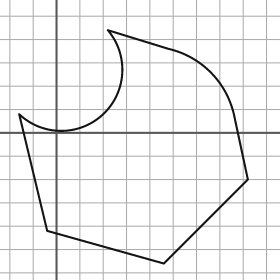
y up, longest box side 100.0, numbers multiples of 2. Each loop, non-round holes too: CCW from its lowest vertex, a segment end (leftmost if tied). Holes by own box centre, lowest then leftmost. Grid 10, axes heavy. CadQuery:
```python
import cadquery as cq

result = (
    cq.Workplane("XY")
    .moveTo(46.0, -56.0)
    .lineTo(82.0, -20.0)
    .lineTo(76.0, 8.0)
    .threePointArc((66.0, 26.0), (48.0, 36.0))
    .lineTo(22.0, 44.0)
    .threePointArc((20.0, 8.0), (-16.0, 8.0))
    .lineTo(-4.0, -42.0)
    .close()
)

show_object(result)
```